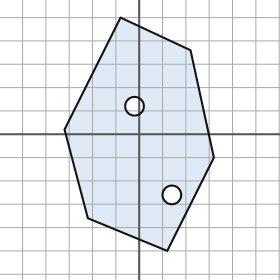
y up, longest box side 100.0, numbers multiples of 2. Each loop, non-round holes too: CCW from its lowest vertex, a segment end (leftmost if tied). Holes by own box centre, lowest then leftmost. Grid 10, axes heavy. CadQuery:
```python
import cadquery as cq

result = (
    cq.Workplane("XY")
    .moveTo(12.0, -50.0)
    .lineTo(32.0, -10.0)
    .lineTo(22.0, 36.0)
    .lineTo(-8.0, 50.0)
    .lineTo(-32.0, 2.0)
    .lineTo(-22.0, -36.0)
    .close()
    .moveTo(14.0, -26.0)
    .circle(4.0)
    .moveTo(-2.0, 12.0)
    .circle(4.0)
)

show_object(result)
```